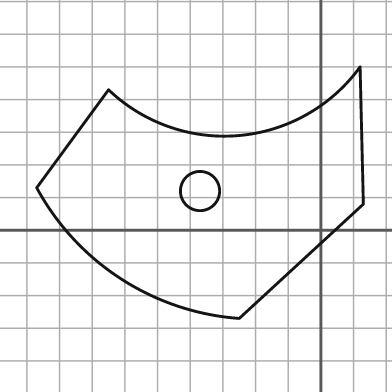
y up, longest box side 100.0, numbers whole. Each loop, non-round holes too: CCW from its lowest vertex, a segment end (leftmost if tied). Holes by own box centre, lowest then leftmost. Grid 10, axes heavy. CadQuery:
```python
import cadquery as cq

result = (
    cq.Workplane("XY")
    .moveTo(-25.0, -27.0)
    .lineTo(13.0, 8.0)
    .lineTo(12.0, 50.0)
    .threePointArc((-25.0, 29.0), (-65.0, 43.0))
    .lineTo(-87.0, 13.0)
    .threePointArc((-61.0, -15.0), (-25.0, -27.0))
    .close()
    .moveTo(-37.0, 12.0)
    .circle(6.0)
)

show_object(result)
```